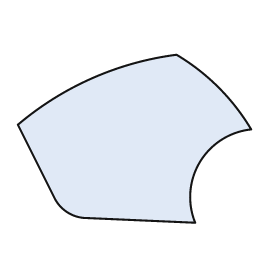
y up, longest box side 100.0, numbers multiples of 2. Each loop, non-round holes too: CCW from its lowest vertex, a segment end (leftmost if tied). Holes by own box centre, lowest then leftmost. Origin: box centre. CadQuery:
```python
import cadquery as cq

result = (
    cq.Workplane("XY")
    .moveTo(26.0, -36.0)
    .threePointArc((28.0, -10.0), (50.0, 4.0))
    .threePointArc((36.0, 22.0), (18.0, 36.0))
    .threePointArc((-18.0, 26.0), (-50.0, 6.0))
    .lineTo(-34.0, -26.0)
    .threePointArc((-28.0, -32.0), (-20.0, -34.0))
    .close()
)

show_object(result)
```